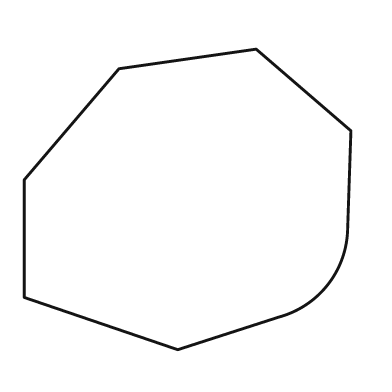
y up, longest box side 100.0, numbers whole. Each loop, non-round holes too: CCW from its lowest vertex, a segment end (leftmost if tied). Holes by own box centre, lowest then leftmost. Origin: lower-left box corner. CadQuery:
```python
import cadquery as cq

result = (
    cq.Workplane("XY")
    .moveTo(47.0, 0.0)
    .lineTo(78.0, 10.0)
    .threePointArc((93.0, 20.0), (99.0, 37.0))
    .lineTo(100.0, 67.0)
    .lineTo(71.0, 92.0)
    .lineTo(29.0, 86.0)
    .lineTo(0.0, 52.0)
    .lineTo(0.0, 16.0)
    .close()
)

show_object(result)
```